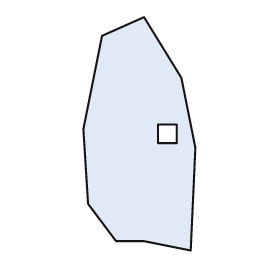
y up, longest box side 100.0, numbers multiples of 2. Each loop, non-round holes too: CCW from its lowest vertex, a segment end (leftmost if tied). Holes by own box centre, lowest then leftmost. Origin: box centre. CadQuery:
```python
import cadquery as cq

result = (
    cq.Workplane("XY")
    .moveTo(22.0, -50.0)
    .lineTo(24.0, -6.0)
    .lineTo(18.0, 24.0)
    .lineTo(2.0, 50.0)
    .lineTo(-16.0, 42.0)
    .lineTo(-24.0, 2.0)
    .lineTo(-22.0, -30.0)
    .lineTo(-10.0, -46.0)
    .lineTo(2.0, -46.0)
    .close()
    .moveTo(8.0, -4.0)
    .lineTo(16.0, -4.0)
    .lineTo(16.0, 4.0)
    .lineTo(8.0, 4.0)
    .close()
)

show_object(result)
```